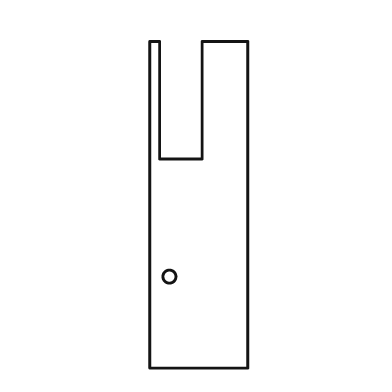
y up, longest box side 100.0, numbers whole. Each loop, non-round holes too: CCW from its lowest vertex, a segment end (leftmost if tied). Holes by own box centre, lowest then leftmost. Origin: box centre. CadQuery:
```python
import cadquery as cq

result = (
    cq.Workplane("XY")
    .moveTo(-15.0, -50.0)
    .lineTo(15.0, -50.0)
    .lineTo(15.0, 50.0)
    .lineTo(1.0, 50.0)
    .lineTo(1.0, 14.0)
    .lineTo(-12.0, 14.0)
    .lineTo(-12.0, 50.0)
    .lineTo(-15.0, 50.0)
    .close()
    .moveTo(-9.0, -22.0)
    .circle(2.0)
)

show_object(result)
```